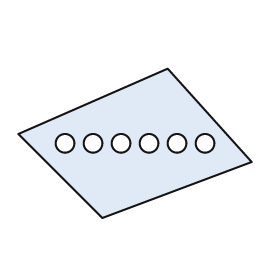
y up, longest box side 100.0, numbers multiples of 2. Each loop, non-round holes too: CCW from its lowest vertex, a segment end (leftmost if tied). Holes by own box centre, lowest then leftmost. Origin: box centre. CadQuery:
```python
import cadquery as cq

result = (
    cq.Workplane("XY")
    .moveTo(-14.0, -32.0)
    .lineTo(50.0, -8.0)
    .lineTo(14.0, 32.0)
    .lineTo(-50.0, 4.0)
    .close()
    .moveTo(-30.0, 0.0)
    .circle(4.0)
    .moveTo(-18.0, 0.0)
    .circle(4.0)
    .moveTo(-6.0, 0.0)
    .circle(4.0)
    .moveTo(6.0, 0.0)
    .circle(4.0)
    .moveTo(18.0, 0.0)
    .circle(4.0)
    .moveTo(30.0, 0.0)
    .circle(4.0)
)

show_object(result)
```